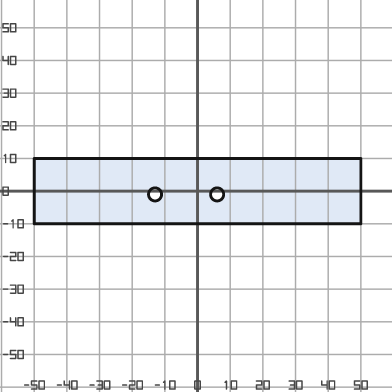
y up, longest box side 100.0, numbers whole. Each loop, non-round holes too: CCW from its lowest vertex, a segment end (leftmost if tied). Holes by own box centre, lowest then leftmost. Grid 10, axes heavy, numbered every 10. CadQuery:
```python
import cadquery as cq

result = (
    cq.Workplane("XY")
    .moveTo(-50.0, -10.0)
    .lineTo(50.0, -10.0)
    .lineTo(50.0, 10.0)
    .lineTo(-50.0, 10.0)
    .close()
    .moveTo(-13.0, -1.0)
    .circle(2.0)
    .moveTo(6.0, -1.0)
    .circle(2.0)
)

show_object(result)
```